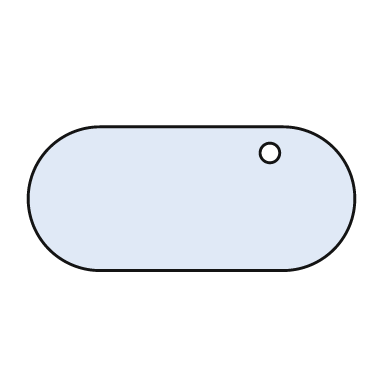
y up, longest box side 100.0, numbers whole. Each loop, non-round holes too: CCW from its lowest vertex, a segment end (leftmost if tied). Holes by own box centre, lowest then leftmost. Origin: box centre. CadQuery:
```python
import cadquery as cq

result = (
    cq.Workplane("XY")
    .moveTo(-28.0, -22.0)
    .lineTo(28.0, -22.0)
    .threePointArc((50.0, 0.0), (28.0, 22.0))
    .lineTo(-28.0, 22.0)
    .threePointArc((-50.0, 0.0), (-28.0, -22.0))
    .close()
    .moveTo(24.0, 14.0)
    .circle(3.0)
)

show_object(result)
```